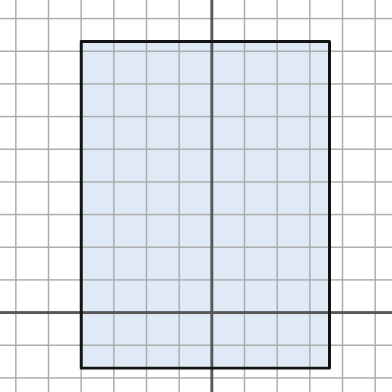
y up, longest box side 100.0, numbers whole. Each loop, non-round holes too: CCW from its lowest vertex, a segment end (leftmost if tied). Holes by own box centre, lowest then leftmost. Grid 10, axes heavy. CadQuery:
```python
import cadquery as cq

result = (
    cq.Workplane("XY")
    .moveTo(-40.0, -17.0)
    .lineTo(36.0, -17.0)
    .lineTo(36.0, 83.0)
    .lineTo(-40.0, 83.0)
    .close()
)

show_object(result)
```